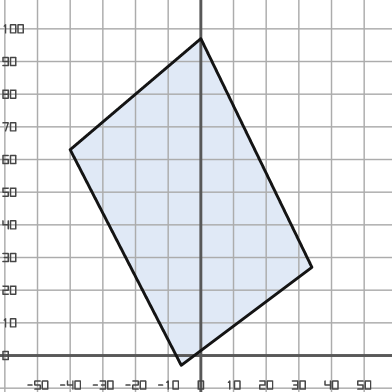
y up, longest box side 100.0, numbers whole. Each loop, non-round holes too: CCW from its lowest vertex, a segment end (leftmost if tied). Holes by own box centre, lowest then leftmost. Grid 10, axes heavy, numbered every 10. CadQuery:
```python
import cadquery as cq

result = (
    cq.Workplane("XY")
    .moveTo(-6.0, -3.0)
    .lineTo(34.0, 27.0)
    .lineTo(0.0, 97.0)
    .lineTo(-40.0, 63.0)
    .close()
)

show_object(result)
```